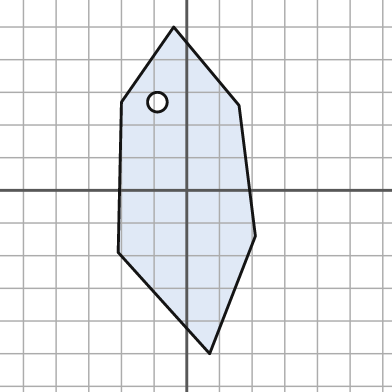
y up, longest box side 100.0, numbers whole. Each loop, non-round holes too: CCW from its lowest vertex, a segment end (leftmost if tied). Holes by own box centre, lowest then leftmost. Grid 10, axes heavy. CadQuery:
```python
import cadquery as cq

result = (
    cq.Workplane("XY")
    .moveTo(7.0, -50.0)
    .lineTo(21.0, -14.0)
    .lineTo(16.0, 26.0)
    .lineTo(-4.0, 50.0)
    .lineTo(-20.0, 27.0)
    .lineTo(-21.0, -19.0)
    .close()
    .moveTo(-9.0, 27.0)
    .circle(3.0)
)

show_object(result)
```